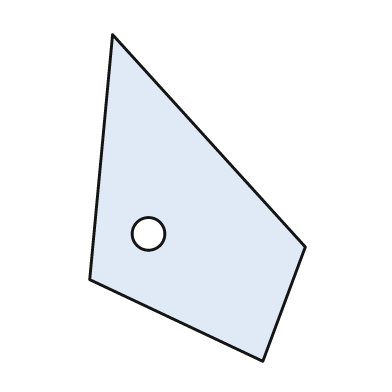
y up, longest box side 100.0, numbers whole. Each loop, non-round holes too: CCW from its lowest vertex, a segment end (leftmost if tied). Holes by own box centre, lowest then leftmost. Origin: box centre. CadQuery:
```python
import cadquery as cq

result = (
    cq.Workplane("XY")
    .moveTo(20.0, -50.0)
    .lineTo(33.0, -15.0)
    .lineTo(-26.0, 50.0)
    .lineTo(-33.0, -25.0)
    .close()
    .moveTo(-15.0, -11.0)
    .circle(5.0)
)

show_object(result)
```